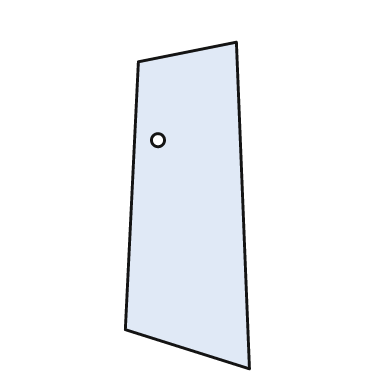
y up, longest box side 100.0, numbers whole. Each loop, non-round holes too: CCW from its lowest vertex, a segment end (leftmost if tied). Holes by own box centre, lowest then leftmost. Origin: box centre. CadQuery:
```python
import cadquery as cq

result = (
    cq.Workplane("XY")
    .moveTo(19.0, -50.0)
    .lineTo(15.0, 50.0)
    .lineTo(-15.0, 44.0)
    .lineTo(-19.0, -38.0)
    .close()
    .moveTo(-9.0, 20.0)
    .circle(2.0)
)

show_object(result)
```